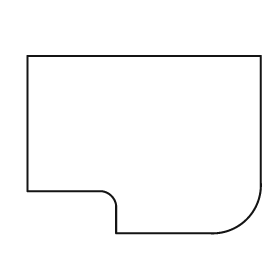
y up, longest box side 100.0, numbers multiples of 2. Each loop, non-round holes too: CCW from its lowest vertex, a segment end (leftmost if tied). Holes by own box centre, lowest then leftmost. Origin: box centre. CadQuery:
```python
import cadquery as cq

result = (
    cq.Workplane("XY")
    .moveTo(-12.0, -38.0)
    .lineTo(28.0, -38.0)
    .threePointArc((44.0, -32.0), (50.0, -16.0))
    .lineTo(50.0, 38.0)
    .lineTo(-50.0, 38.0)
    .lineTo(-50.0, -20.0)
    .lineTo(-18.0, -20.0)
    .threePointArc((-14.0, -22.0), (-12.0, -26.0))
    .close()
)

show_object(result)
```